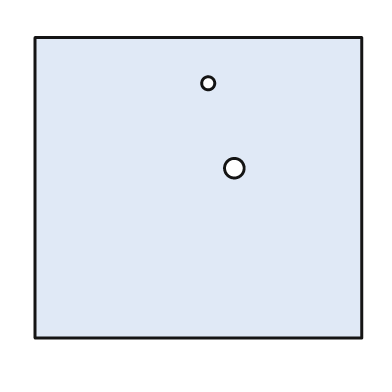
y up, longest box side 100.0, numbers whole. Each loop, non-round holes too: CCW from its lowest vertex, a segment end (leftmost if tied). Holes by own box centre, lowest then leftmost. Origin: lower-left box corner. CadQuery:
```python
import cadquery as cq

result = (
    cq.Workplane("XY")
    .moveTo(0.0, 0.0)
    .lineTo(100.0, 0.0)
    .lineTo(100.0, 92.0)
    .lineTo(0.0, 92.0)
    .close()
    .moveTo(61.0, 52.0)
    .circle(3.0)
    .moveTo(53.0, 78.0)
    .circle(2.0)
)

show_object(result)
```